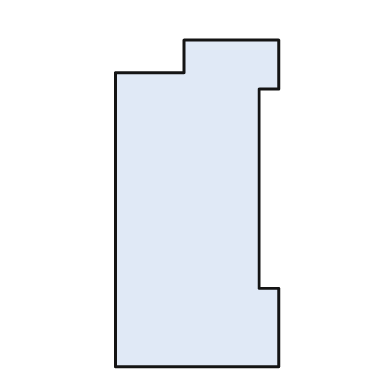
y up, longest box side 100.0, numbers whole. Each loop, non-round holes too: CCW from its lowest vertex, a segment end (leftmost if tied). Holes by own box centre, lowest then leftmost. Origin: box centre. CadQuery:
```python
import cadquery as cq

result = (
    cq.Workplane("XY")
    .moveTo(-25.0, -50.0)
    .lineTo(25.0, -50.0)
    .lineTo(25.0, -26.0)
    .lineTo(19.0, -26.0)
    .lineTo(19.0, 35.0)
    .lineTo(25.0, 35.0)
    .lineTo(25.0, 50.0)
    .lineTo(-4.0, 50.0)
    .lineTo(-4.0, 40.0)
    .lineTo(-25.0, 40.0)
    .close()
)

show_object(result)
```